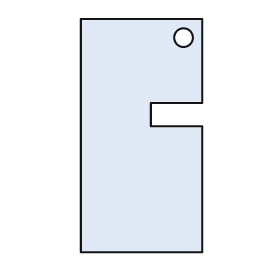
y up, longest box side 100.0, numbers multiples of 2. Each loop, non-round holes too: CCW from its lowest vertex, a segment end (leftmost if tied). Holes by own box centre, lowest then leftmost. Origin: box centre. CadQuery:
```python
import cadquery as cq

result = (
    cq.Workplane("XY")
    .moveTo(-26.0, -50.0)
    .lineTo(26.0, -50.0)
    .lineTo(26.0, 4.0)
    .lineTo(4.0, 4.0)
    .lineTo(4.0, 14.0)
    .lineTo(26.0, 14.0)
    .lineTo(26.0, 50.0)
    .lineTo(-26.0, 50.0)
    .close()
    .moveTo(18.0, 42.0)
    .circle(4.0)
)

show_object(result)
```